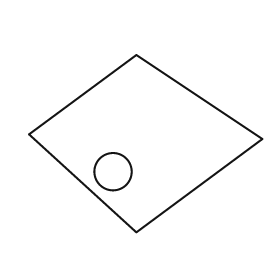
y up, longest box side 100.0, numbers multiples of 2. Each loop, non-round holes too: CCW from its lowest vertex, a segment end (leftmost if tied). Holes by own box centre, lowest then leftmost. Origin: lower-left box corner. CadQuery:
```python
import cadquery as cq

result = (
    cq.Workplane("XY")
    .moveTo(46.0, 0.0)
    .lineTo(100.0, 40.0)
    .lineTo(46.0, 76.0)
    .lineTo(0.0, 42.0)
    .close()
    .moveTo(36.0, 26.0)
    .circle(8.0)
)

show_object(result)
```